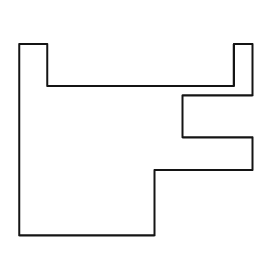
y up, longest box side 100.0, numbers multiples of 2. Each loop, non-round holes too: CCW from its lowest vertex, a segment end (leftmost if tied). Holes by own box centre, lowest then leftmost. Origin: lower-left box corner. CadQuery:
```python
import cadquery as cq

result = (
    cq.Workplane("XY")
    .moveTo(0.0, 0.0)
    .lineTo(58.0, 0.0)
    .lineTo(58.0, 28.0)
    .lineTo(100.0, 28.0)
    .lineTo(100.0, 42.0)
    .lineTo(70.0, 42.0)
    .lineTo(70.0, 60.0)
    .lineTo(100.0, 60.0)
    .lineTo(100.0, 82.0)
    .lineTo(92.0, 82.0)
    .lineTo(92.0, 64.0)
    .lineTo(12.0, 64.0)
    .lineTo(12.0, 82.0)
    .lineTo(0.0, 82.0)
    .close()
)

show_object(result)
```